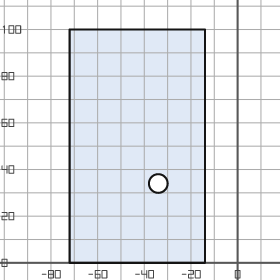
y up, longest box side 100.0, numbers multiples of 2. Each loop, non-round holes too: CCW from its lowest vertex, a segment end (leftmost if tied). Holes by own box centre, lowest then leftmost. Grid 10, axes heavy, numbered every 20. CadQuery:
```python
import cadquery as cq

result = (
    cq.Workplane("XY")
    .moveTo(-72.0, 0.0)
    .lineTo(-14.0, 0.0)
    .lineTo(-14.0, 100.0)
    .lineTo(-72.0, 100.0)
    .close()
    .moveTo(-34.0, 34.0)
    .circle(4.0)
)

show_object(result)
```